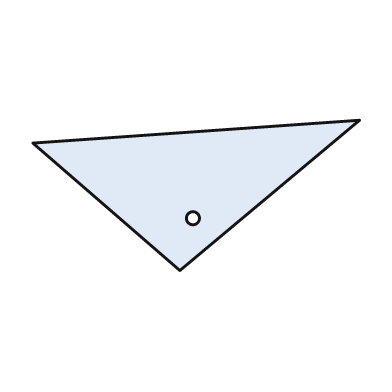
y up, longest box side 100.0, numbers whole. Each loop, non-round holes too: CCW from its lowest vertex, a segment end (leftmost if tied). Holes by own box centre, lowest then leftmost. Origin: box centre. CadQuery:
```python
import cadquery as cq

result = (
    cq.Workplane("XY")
    .moveTo(-5.0, -23.0)
    .lineTo(50.0, 23.0)
    .lineTo(-50.0, 16.0)
    .close()
    .moveTo(-1.0, -7.0)
    .circle(2.0)
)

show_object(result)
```